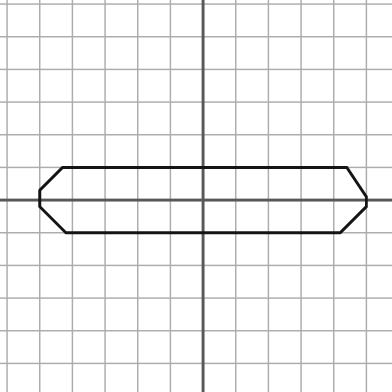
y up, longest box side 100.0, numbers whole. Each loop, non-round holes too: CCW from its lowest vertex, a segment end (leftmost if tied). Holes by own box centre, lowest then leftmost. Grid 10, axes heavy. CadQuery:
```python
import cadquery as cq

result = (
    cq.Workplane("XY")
    .moveTo(-42.0, -10.0)
    .lineTo(42.0, -10.0)
    .lineTo(50.0, -2.0)
    .lineTo(50.0, 1.0)
    .lineTo(44.0, 10.0)
    .lineTo(-43.0, 10.0)
    .lineTo(-50.0, 3.0)
    .lineTo(-50.0, -2.0)
    .close()
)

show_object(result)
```